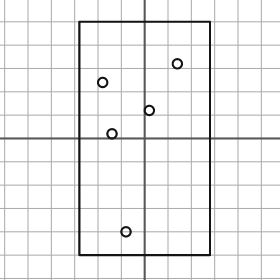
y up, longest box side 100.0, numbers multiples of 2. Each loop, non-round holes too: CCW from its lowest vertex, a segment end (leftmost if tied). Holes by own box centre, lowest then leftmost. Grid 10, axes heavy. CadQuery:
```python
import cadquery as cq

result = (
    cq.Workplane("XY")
    .moveTo(-28.0, -50.0)
    .lineTo(28.0, -50.0)
    .lineTo(28.0, 50.0)
    .lineTo(-28.0, 50.0)
    .close()
    .moveTo(-8.0, -40.0)
    .circle(2.0)
    .moveTo(-14.0, 2.0)
    .circle(2.0)
    .moveTo(2.0, 12.0)
    .circle(2.0)
    .moveTo(-18.0, 24.0)
    .circle(2.0)
    .moveTo(14.0, 32.0)
    .circle(2.0)
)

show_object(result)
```